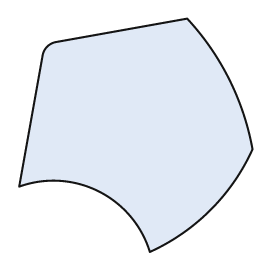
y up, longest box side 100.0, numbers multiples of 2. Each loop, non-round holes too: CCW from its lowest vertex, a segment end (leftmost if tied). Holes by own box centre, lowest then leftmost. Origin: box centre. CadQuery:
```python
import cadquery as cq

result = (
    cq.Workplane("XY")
    .moveTo(6.0, -50.0)
    .threePointArc((32.0, -32.0), (50.0, -6.0))
    .threePointArc((40.0, 24.0), (22.0, 50.0))
    .lineTo(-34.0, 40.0)
    .threePointArc((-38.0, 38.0), (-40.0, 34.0))
    .lineTo(-50.0, -22.0)
    .threePointArc((-16.0, -24.0), (6.0, -50.0))
    .close()
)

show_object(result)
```